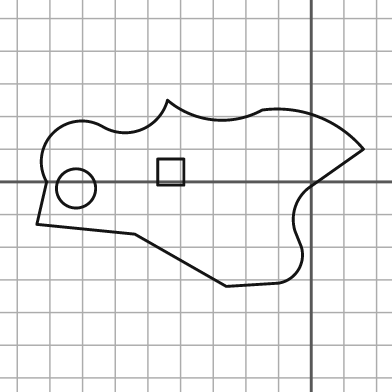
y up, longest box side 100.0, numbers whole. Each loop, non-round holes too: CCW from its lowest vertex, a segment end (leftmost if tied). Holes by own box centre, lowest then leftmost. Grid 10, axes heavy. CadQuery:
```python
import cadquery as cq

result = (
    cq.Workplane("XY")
    .moveTo(-26.0, -32.0)
    .lineTo(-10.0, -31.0)
    .threePointArc((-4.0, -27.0), (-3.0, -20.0))
    .lineTo(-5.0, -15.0)
    .threePointArc((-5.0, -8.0), (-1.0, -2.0))
    .lineTo(16.0, 10.0)
    .threePointArc((2.0, 20.0), (-15.0, 22.0))
    .threePointArc((-30.0, 19.0), (-44.0, 25.0))
    .threePointArc((-52.0, 16.0), (-64.0, 17.0))
    .threePointArc((-79.0, 15.0), (-81.0, 0.0))
    .lineTo(-84.0, -13.0)
    .lineTo(-54.0, -16.0)
    .close()
    .moveTo(-72.0, -2.0)
    .circle(6.0)
    .moveTo(-47.0, -1.0)
    .lineTo(-39.0, -1.0)
    .lineTo(-39.0, 7.0)
    .lineTo(-47.0, 7.0)
    .close()
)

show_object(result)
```